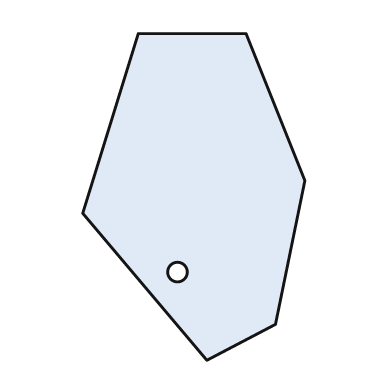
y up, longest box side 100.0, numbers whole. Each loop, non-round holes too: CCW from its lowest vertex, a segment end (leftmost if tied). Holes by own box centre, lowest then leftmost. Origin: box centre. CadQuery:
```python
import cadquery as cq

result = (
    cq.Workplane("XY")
    .moveTo(4.0, -50.0)
    .lineTo(25.0, -39.0)
    .lineTo(34.0, 5.0)
    .lineTo(16.0, 50.0)
    .lineTo(-17.0, 50.0)
    .lineTo(-34.0, -5.0)
    .close()
    .moveTo(-5.0, -23.0)
    .circle(3.0)
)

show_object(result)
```